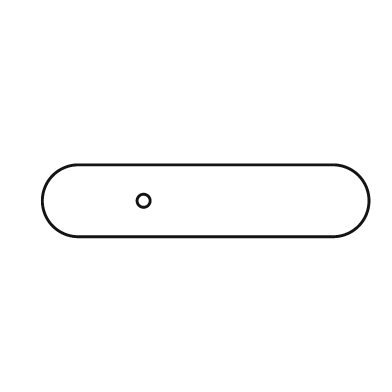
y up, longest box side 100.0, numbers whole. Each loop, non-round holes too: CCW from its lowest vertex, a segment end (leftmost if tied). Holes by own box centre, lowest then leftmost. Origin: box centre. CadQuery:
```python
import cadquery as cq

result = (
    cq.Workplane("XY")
    .moveTo(-39.0, -11.0)
    .lineTo(39.0, -11.0)
    .threePointArc((50.0, 0.0), (39.0, 11.0))
    .lineTo(-39.0, 11.0)
    .threePointArc((-50.0, 0.0), (-39.0, -11.0))
    .close()
    .moveTo(-19.0, 0.0)
    .circle(2.0)
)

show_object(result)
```